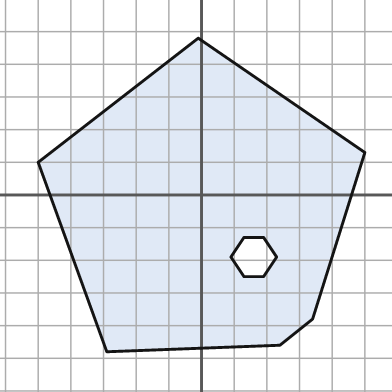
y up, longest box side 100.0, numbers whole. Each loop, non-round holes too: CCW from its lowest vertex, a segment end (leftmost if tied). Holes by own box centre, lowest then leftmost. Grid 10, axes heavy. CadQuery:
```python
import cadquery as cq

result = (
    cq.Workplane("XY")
    .moveTo(-29.0, -48.0)
    .lineTo(24.0, -46.0)
    .lineTo(34.0, -38.0)
    .lineTo(50.0, 13.0)
    .lineTo(-1.0, 48.0)
    .lineTo(-50.0, 10.0)
    .close()
    .moveTo(13.0, -25.0)
    .lineTo(19.0, -25.0)
    .lineTo(23.0, -19.0)
    .lineTo(19.0, -13.0)
    .lineTo(13.0, -13.0)
    .lineTo(9.0, -19.0)
    .close()
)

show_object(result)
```